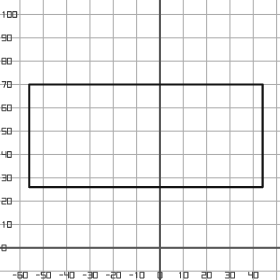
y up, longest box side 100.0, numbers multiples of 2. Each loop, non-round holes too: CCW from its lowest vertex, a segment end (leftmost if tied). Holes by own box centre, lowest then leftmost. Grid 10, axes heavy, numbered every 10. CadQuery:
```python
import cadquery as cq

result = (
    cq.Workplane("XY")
    .moveTo(-56.0, 26.0)
    .lineTo(44.0, 26.0)
    .lineTo(44.0, 70.0)
    .lineTo(-56.0, 70.0)
    .close()
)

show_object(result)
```